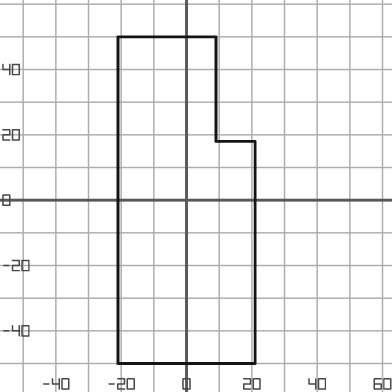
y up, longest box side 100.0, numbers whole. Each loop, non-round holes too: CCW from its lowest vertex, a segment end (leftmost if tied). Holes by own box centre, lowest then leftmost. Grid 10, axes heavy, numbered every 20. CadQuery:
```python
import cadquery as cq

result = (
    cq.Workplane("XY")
    .moveTo(-21.0, -50.0)
    .lineTo(21.0, -50.0)
    .lineTo(21.0, 18.0)
    .lineTo(9.0, 18.0)
    .lineTo(9.0, 50.0)
    .lineTo(-21.0, 50.0)
    .close()
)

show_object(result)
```